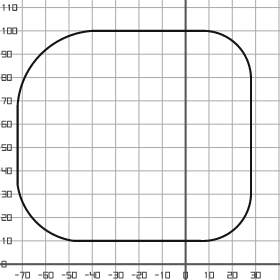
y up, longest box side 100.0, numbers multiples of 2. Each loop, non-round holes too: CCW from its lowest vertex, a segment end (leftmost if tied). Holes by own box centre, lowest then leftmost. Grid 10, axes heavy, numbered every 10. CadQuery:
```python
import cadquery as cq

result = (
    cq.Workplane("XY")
    .moveTo(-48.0, 10.0)
    .lineTo(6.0, 10.0)
    .threePointArc((22.0, 16.0), (28.0, 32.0))
    .lineTo(28.0, 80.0)
    .threePointArc((22.0, 94.0), (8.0, 100.0))
    .lineTo(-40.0, 100.0)
    .threePointArc((-62.0, 90.0), (-72.0, 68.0))
    .lineTo(-72.0, 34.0)
    .threePointArc((-64.0, 18.0), (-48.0, 10.0))
    .close()
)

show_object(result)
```